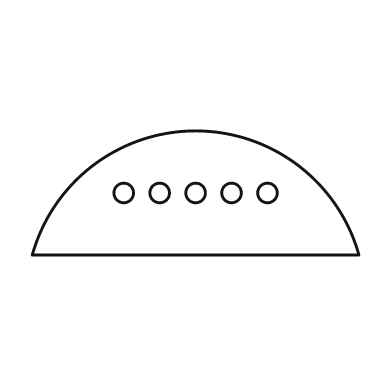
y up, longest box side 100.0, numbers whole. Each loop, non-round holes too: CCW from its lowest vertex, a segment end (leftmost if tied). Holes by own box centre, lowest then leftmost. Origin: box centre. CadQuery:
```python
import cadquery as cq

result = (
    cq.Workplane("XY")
    .moveTo(-50.0, -19.0)
    .lineTo(50.0, -19.0)
    .threePointArc((0.0, 19.0), (-50.0, -19.0))
    .close()
    .moveTo(-22.0, 0.0)
    .circle(3.0)
    .moveTo(-11.0, 0.0)
    .circle(3.0)
    .moveTo(0.0, 0.0)
    .circle(3.0)
    .moveTo(11.0, 0.0)
    .circle(3.0)
    .moveTo(22.0, 0.0)
    .circle(3.0)
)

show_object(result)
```